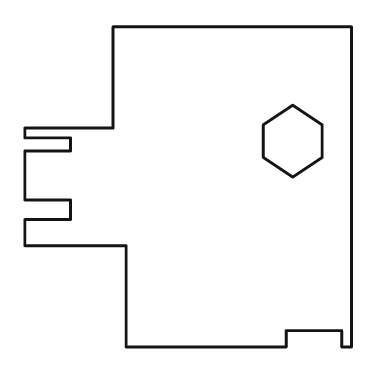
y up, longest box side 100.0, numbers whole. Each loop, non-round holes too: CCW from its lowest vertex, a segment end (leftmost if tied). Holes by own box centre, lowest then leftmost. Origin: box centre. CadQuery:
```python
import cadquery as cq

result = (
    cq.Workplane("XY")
    .moveTo(-19.0, -49.0)
    .lineTo(30.0, -49.0)
    .lineTo(30.0, -44.0)
    .lineTo(47.0, -44.0)
    .lineTo(47.0, -49.0)
    .lineTo(50.0, -49.0)
    .lineTo(50.0, 49.0)
    .lineTo(-23.0, 49.0)
    .lineTo(-23.0, 18.0)
    .lineTo(-50.0, 18.0)
    .lineTo(-50.0, 15.0)
    .lineTo(-36.0, 15.0)
    .lineTo(-36.0, 11.0)
    .lineTo(-50.0, 11.0)
    .lineTo(-50.0, -4.0)
    .lineTo(-36.0, -4.0)
    .lineTo(-36.0, -10.0)
    .lineTo(-50.0, -10.0)
    .lineTo(-50.0, -18.0)
    .lineTo(-19.0, -18.0)
    .close()
    .moveTo(32.0, 3.0)
    .lineTo(41.0, 9.0)
    .lineTo(41.0, 19.0)
    .lineTo(32.0, 25.0)
    .lineTo(23.0, 19.0)
    .lineTo(23.0, 9.0)
    .close()
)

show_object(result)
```